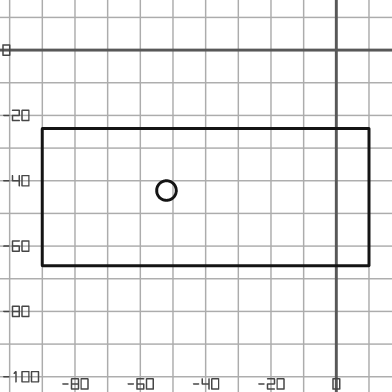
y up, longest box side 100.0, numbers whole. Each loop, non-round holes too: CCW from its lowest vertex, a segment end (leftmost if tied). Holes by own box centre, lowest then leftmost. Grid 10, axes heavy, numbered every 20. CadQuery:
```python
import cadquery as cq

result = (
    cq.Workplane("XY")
    .moveTo(-90.0, -66.0)
    .lineTo(10.0, -66.0)
    .lineTo(10.0, -24.0)
    .lineTo(-90.0, -24.0)
    .close()
    .moveTo(-52.0, -43.0)
    .circle(3.0)
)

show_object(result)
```